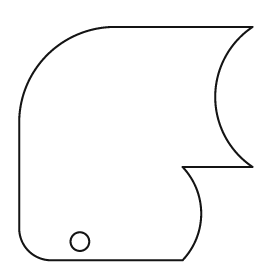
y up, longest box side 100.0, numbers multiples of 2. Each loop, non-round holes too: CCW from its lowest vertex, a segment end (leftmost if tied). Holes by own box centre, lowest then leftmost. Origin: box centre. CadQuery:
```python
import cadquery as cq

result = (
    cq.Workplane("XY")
    .moveTo(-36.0, -50.0)
    .lineTo(20.0, -50.0)
    .threePointArc((28.0, -30.0), (20.0, -10.0))
    .lineTo(50.0, -10.0)
    .threePointArc((34.0, 20.0), (50.0, 50.0))
    .lineTo(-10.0, 50.0)
    .threePointArc((-38.0, 38.0), (-50.0, 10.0))
    .lineTo(-50.0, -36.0)
    .threePointArc((-46.0, -46.0), (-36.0, -50.0))
    .close()
    .moveTo(-24.0, -42.0)
    .circle(4.0)
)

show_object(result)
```